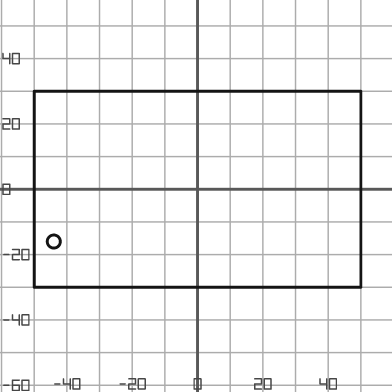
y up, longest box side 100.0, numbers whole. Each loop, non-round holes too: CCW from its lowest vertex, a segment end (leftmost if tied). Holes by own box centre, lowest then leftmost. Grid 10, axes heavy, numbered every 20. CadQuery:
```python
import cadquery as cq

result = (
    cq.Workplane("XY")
    .moveTo(-50.0, -30.0)
    .lineTo(50.0, -30.0)
    .lineTo(50.0, 30.0)
    .lineTo(-50.0, 30.0)
    .close()
    .moveTo(-44.0, -16.0)
    .circle(2.0)
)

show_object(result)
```